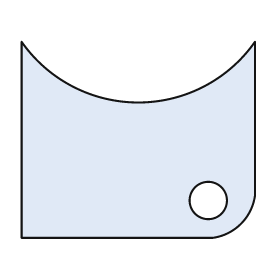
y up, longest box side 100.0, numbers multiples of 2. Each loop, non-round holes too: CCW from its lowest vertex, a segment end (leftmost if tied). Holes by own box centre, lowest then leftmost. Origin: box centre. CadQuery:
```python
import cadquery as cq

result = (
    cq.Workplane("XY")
    .moveTo(-50.0, -42.0)
    .lineTo(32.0, -42.0)
    .threePointArc((44.0, -36.0), (50.0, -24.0))
    .lineTo(50.0, 42.0)
    .threePointArc((0.0, 16.0), (-50.0, 42.0))
    .close()
    .moveTo(30.0, -26.0)
    .circle(8.0)
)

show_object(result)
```